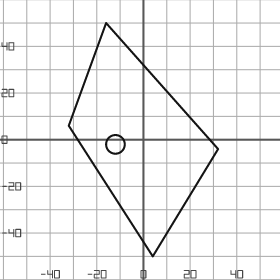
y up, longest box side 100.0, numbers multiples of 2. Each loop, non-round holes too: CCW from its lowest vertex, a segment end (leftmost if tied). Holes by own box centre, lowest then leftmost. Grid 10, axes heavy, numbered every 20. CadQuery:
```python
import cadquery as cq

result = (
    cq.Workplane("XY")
    .moveTo(4.0, -50.0)
    .lineTo(32.0, -4.0)
    .lineTo(-16.0, 50.0)
    .lineTo(-32.0, 6.0)
    .close()
    .moveTo(-12.0, -2.0)
    .circle(4.0)
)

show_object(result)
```